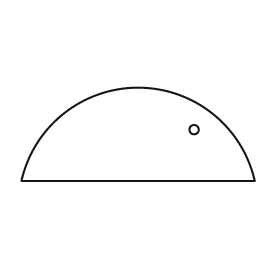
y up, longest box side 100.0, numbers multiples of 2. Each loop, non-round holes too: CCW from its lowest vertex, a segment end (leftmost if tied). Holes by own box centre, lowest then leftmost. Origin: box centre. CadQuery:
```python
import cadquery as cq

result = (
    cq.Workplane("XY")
    .moveTo(-50.0, -20.0)
    .lineTo(50.0, -20.0)
    .threePointArc((0.0, 20.0), (-50.0, -20.0))
    .close()
    .moveTo(24.0, 2.0)
    .circle(2.0)
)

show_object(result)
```